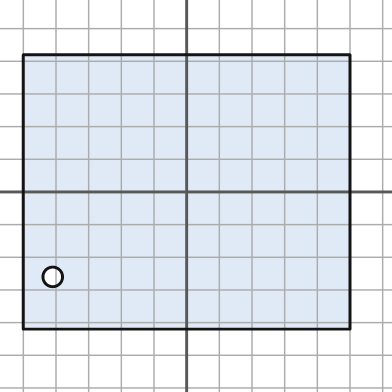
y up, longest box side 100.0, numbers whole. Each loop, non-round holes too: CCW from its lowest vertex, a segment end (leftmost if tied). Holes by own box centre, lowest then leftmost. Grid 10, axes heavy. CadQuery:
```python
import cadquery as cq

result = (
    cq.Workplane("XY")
    .moveTo(-50.0, -42.0)
    .lineTo(50.0, -42.0)
    .lineTo(50.0, 42.0)
    .lineTo(-50.0, 42.0)
    .close()
    .moveTo(-41.0, -26.0)
    .circle(3.0)
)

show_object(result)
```